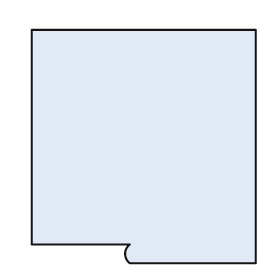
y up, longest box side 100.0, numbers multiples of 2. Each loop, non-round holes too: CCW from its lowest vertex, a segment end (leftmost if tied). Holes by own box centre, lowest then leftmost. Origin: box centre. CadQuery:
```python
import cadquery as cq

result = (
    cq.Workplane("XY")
    .moveTo(-6.0, -50.0)
    .lineTo(48.0, -50.0)
    .lineTo(48.0, 50.0)
    .lineTo(-48.0, 50.0)
    .lineTo(-48.0, -42.0)
    .lineTo(-6.0, -42.0)
    .threePointArc((-8.0, -46.0), (-6.0, -50.0))
    .close()
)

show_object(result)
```